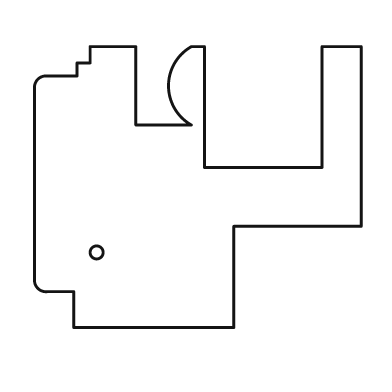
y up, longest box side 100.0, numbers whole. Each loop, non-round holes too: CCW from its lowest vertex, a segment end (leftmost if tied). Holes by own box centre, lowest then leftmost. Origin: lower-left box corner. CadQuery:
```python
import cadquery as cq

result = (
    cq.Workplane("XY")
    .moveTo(12.0, 0.0)
    .lineTo(61.0, 0.0)
    .lineTo(61.0, 31.0)
    .lineTo(100.0, 31.0)
    .lineTo(100.0, 86.0)
    .lineTo(88.0, 86.0)
    .lineTo(88.0, 49.0)
    .lineTo(52.0, 49.0)
    .lineTo(52.0, 86.0)
    .lineTo(48.0, 86.0)
    .threePointArc((41.0, 74.0), (48.0, 62.0))
    .lineTo(31.0, 62.0)
    .lineTo(31.0, 86.0)
    .lineTo(17.0, 86.0)
    .lineTo(17.0, 81.0)
    .lineTo(13.0, 81.0)
    .lineTo(13.0, 77.0)
    .lineTo(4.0, 77.0)
    .threePointArc((1.0, 76.0), (0.0, 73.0))
    .lineTo(0.0, 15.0)
    .threePointArc((1.0, 12.0), (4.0, 11.0))
    .lineTo(12.0, 11.0)
    .close()
    .moveTo(19.0, 23.0)
    .circle(2.0)
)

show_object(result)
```